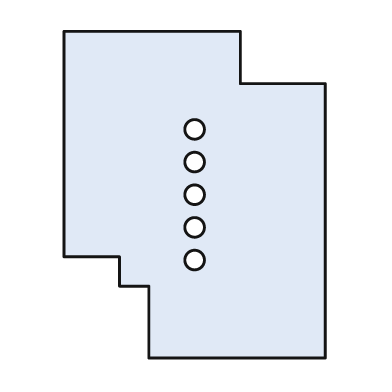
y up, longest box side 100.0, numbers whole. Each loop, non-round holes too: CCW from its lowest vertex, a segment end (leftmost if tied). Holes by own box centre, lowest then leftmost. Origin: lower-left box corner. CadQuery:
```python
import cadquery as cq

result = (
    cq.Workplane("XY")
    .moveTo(26.0, 0.0)
    .lineTo(80.0, 0.0)
    .lineTo(80.0, 84.0)
    .lineTo(54.0, 84.0)
    .lineTo(54.0, 100.0)
    .lineTo(0.0, 100.0)
    .lineTo(0.0, 31.0)
    .lineTo(17.0, 31.0)
    .lineTo(17.0, 22.0)
    .lineTo(26.0, 22.0)
    .close()
    .moveTo(40.0, 30.0)
    .circle(3.0)
    .moveTo(40.0, 40.0)
    .circle(3.0)
    .moveTo(40.0, 50.0)
    .circle(3.0)
    .moveTo(40.0, 60.0)
    .circle(3.0)
    .moveTo(40.0, 70.0)
    .circle(3.0)
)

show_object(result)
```